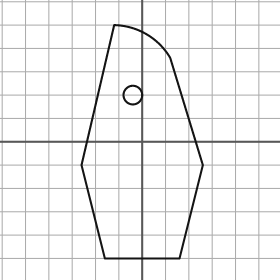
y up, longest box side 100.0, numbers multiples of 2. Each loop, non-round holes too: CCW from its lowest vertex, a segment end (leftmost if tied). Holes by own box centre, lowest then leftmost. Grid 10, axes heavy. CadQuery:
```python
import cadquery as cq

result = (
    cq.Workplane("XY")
    .moveTo(-16.0, -50.0)
    .lineTo(16.0, -50.0)
    .lineTo(26.0, -10.0)
    .lineTo(12.0, 36.0)
    .threePointArc((2.0, 46.0), (-12.0, 50.0))
    .lineTo(-26.0, -10.0)
    .close()
    .moveTo(-4.0, 20.0)
    .circle(4.0)
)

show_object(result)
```